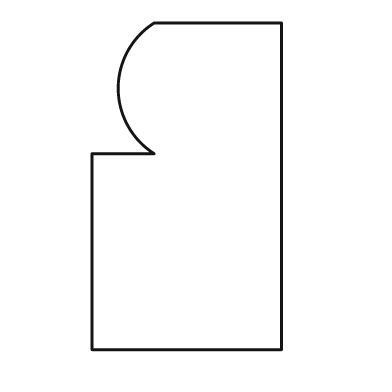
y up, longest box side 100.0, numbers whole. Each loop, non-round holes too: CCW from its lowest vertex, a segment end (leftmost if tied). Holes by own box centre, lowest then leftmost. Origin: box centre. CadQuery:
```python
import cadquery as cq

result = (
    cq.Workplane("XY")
    .moveTo(-29.0, -50.0)
    .lineTo(29.0, -50.0)
    .lineTo(29.0, 50.0)
    .lineTo(-10.0, 50.0)
    .threePointArc((-21.0, 30.0), (-10.0, 10.0))
    .lineTo(-29.0, 10.0)
    .close()
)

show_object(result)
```